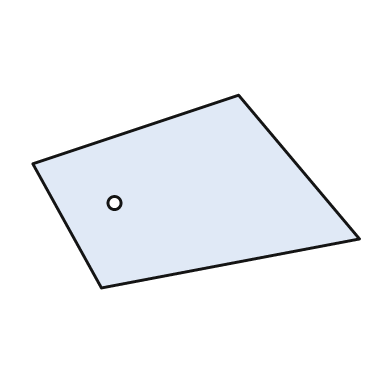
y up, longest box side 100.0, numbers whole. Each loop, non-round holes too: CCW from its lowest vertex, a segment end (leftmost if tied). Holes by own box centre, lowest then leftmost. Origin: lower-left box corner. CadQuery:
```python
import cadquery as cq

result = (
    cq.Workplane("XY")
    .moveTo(21.0, 0.0)
    .lineTo(100.0, 15.0)
    .lineTo(63.0, 59.0)
    .lineTo(0.0, 38.0)
    .close()
    .moveTo(25.0, 26.0)
    .circle(2.0)
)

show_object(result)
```